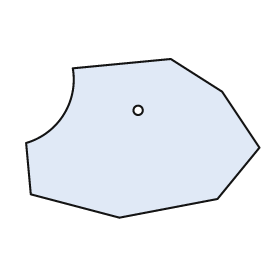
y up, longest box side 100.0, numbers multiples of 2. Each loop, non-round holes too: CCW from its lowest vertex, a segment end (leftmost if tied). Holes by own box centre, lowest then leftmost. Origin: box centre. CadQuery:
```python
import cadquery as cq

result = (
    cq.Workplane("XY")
    .moveTo(-10.0, -34.0)
    .lineTo(32.0, -26.0)
    .lineTo(50.0, -4.0)
    .lineTo(34.0, 20.0)
    .lineTo(12.0, 34.0)
    .lineTo(-30.0, 30.0)
    .threePointArc((-34.0, 10.0), (-50.0, -2.0))
    .lineTo(-48.0, -24.0)
    .close()
    .moveTo(-2.0, 12.0)
    .circle(2.0)
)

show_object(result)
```